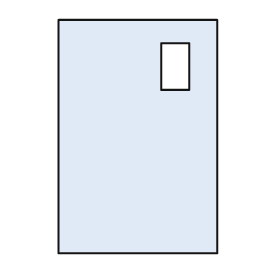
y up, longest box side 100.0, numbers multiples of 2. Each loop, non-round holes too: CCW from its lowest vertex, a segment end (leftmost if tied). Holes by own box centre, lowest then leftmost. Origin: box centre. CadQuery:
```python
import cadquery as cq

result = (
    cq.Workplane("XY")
    .moveTo(-34.0, -50.0)
    .lineTo(34.0, -50.0)
    .lineTo(34.0, 50.0)
    .lineTo(-34.0, 50.0)
    .close()
    .moveTo(10.0, 20.0)
    .lineTo(22.0, 20.0)
    .lineTo(22.0, 40.0)
    .lineTo(10.0, 40.0)
    .close()
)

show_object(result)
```